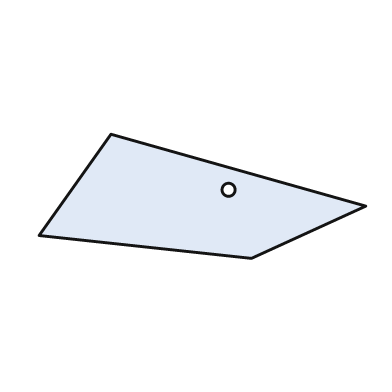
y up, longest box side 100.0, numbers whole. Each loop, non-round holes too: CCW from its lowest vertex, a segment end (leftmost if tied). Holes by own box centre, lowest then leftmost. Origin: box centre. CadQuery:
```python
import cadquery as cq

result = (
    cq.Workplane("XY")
    .moveTo(15.0, -19.0)
    .lineTo(50.0, -3.0)
    .lineTo(-28.0, 19.0)
    .lineTo(-50.0, -12.0)
    .close()
    .moveTo(8.0, 2.0)
    .circle(2.0)
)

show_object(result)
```